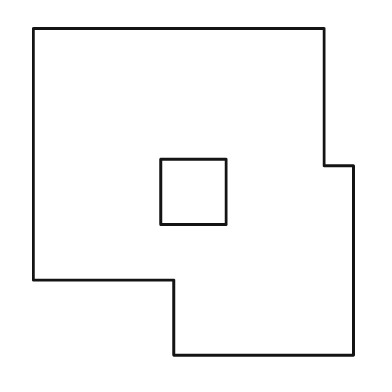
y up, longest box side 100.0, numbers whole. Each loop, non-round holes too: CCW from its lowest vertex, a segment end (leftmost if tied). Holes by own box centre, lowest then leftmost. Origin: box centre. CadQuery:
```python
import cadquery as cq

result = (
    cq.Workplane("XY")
    .moveTo(-6.0, -50.0)
    .lineTo(49.0, -50.0)
    .lineTo(49.0, 8.0)
    .lineTo(40.0, 8.0)
    .lineTo(40.0, 50.0)
    .lineTo(-49.0, 50.0)
    .lineTo(-49.0, -27.0)
    .lineTo(-6.0, -27.0)
    .close()
    .moveTo(-10.0, -10.0)
    .lineTo(10.0, -10.0)
    .lineTo(10.0, 10.0)
    .lineTo(-10.0, 10.0)
    .close()
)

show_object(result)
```